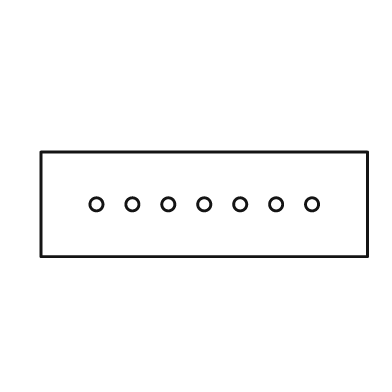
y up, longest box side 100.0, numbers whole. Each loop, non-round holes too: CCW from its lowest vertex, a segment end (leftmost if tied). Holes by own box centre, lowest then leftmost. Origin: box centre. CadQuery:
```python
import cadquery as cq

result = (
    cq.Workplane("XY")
    .moveTo(-50.0, -16.0)
    .lineTo(50.0, -16.0)
    .lineTo(50.0, 16.0)
    .lineTo(-50.0, 16.0)
    .close()
    .moveTo(-33.0, 0.0)
    .circle(2.0)
    .moveTo(-22.0, 0.0)
    .circle(2.0)
    .moveTo(-11.0, 0.0)
    .circle(2.0)
    .moveTo(0.0, 0.0)
    .circle(2.0)
    .moveTo(11.0, 0.0)
    .circle(2.0)
    .moveTo(22.0, 0.0)
    .circle(2.0)
    .moveTo(33.0, 0.0)
    .circle(2.0)
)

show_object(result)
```